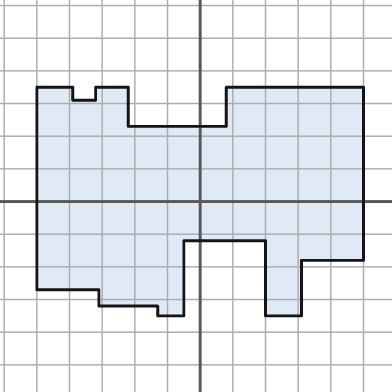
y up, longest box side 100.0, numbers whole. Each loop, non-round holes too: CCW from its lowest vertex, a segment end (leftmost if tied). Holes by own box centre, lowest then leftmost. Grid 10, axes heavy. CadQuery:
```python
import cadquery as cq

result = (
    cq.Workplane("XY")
    .moveTo(-13.0, -35.0)
    .lineTo(-5.0, -35.0)
    .lineTo(-5.0, -12.0)
    .lineTo(20.0, -12.0)
    .lineTo(20.0, -35.0)
    .lineTo(31.0, -35.0)
    .lineTo(31.0, -18.0)
    .lineTo(50.0, -18.0)
    .lineTo(50.0, 35.0)
    .lineTo(8.0, 35.0)
    .lineTo(8.0, 23.0)
    .lineTo(-22.0, 23.0)
    .lineTo(-22.0, 35.0)
    .lineTo(-32.0, 35.0)
    .lineTo(-32.0, 31.0)
    .lineTo(-39.0, 31.0)
    .lineTo(-39.0, 35.0)
    .lineTo(-50.0, 35.0)
    .lineTo(-50.0, -27.0)
    .lineTo(-31.0, -27.0)
    .lineTo(-31.0, -32.0)
    .lineTo(-13.0, -32.0)
    .close()
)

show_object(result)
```